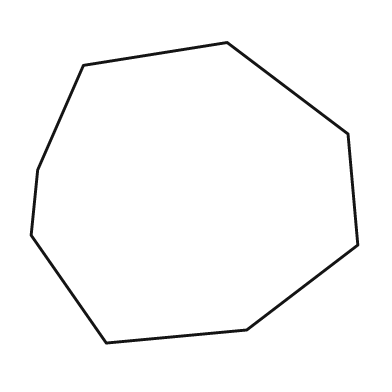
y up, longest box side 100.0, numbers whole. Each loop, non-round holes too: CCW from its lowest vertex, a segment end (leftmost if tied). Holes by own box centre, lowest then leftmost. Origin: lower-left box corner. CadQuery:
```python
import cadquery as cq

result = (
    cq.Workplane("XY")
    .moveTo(23.0, 0.0)
    .lineTo(66.0, 4.0)
    .lineTo(100.0, 30.0)
    .lineTo(97.0, 64.0)
    .lineTo(60.0, 92.0)
    .lineTo(16.0, 85.0)
    .lineTo(2.0, 53.0)
    .lineTo(0.0, 33.0)
    .close()
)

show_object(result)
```